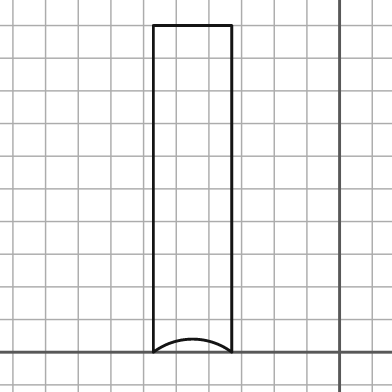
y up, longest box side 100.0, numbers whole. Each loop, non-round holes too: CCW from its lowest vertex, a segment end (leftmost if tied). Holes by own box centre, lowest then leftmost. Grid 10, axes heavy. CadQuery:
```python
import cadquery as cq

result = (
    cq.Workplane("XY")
    .moveTo(-57.0, 0.0)
    .threePointArc((-45.0, 4.0), (-33.0, 0.0))
    .lineTo(-33.0, 100.0)
    .lineTo(-57.0, 100.0)
    .close()
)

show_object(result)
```